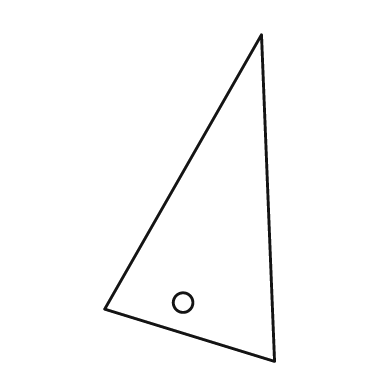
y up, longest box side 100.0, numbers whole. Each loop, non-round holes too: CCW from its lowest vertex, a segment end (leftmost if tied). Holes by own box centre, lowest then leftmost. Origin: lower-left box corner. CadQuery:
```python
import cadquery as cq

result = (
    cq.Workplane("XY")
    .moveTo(52.0, 0.0)
    .lineTo(48.0, 100.0)
    .lineTo(0.0, 16.0)
    .close()
    .moveTo(24.0, 18.0)
    .circle(3.0)
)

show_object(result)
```